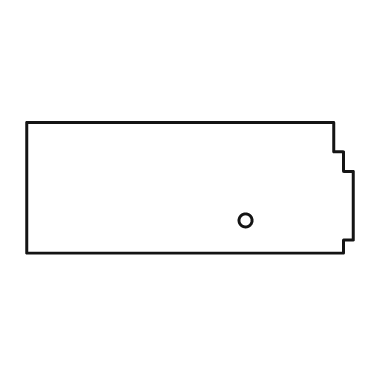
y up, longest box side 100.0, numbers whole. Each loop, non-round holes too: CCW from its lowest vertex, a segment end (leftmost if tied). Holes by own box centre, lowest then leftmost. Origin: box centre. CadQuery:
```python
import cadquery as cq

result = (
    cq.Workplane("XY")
    .moveTo(-50.0, -20.0)
    .lineTo(47.0, -20.0)
    .lineTo(47.0, -16.0)
    .lineTo(50.0, -16.0)
    .lineTo(50.0, 5.0)
    .lineTo(47.0, 5.0)
    .lineTo(47.0, 11.0)
    .lineTo(44.0, 11.0)
    .lineTo(44.0, 20.0)
    .lineTo(-50.0, 20.0)
    .close()
    .moveTo(17.0, -10.0)
    .circle(2.0)
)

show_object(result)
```